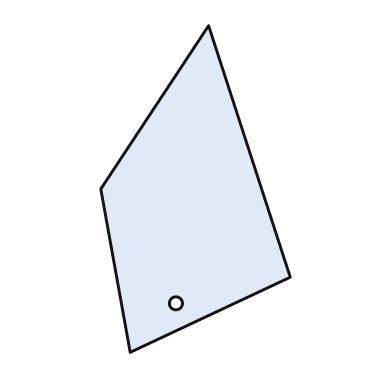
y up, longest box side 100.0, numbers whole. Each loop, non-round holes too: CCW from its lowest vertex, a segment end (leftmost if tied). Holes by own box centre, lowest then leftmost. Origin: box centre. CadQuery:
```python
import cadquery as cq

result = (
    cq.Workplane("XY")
    .moveTo(-20.0, -50.0)
    .lineTo(29.0, -27.0)
    .lineTo(4.0, 50.0)
    .lineTo(-29.0, 0.0)
    .close()
    .moveTo(-6.0, -35.0)
    .circle(2.0)
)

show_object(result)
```